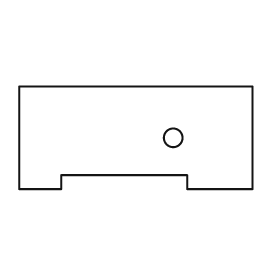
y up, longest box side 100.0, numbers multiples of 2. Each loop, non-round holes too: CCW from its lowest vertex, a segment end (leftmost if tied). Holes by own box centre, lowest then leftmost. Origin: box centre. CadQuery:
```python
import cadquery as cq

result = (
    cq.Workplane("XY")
    .moveTo(-50.0, -22.0)
    .lineTo(-32.0, -22.0)
    .lineTo(-32.0, -16.0)
    .lineTo(22.0, -16.0)
    .lineTo(22.0, -22.0)
    .lineTo(50.0, -22.0)
    .lineTo(50.0, 22.0)
    .lineTo(-50.0, 22.0)
    .close()
    .moveTo(16.0, 0.0)
    .circle(4.0)
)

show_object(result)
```